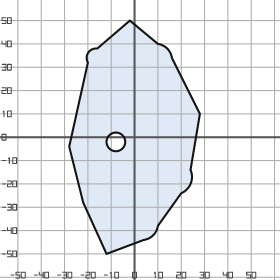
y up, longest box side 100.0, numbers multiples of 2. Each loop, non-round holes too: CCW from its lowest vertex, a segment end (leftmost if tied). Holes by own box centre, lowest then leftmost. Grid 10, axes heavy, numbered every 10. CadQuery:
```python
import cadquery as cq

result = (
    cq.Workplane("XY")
    .moveTo(-12.0, -50.0)
    .lineTo(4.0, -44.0)
    .threePointArc((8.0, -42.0), (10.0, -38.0))
    .lineTo(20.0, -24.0)
    .threePointArc((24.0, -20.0), (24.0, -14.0))
    .lineTo(28.0, 10.0)
    .lineTo(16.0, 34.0)
    .threePointArc((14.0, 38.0), (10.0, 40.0))
    .lineTo(-2.0, 50.0)
    .lineTo(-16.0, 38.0)
    .threePointArc((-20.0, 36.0), (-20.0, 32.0))
    .lineTo(-28.0, -4.0)
    .lineTo(-22.0, -28.0)
    .close()
    .moveTo(-8.0, -2.0)
    .circle(4.0)
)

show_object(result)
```